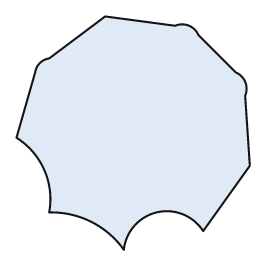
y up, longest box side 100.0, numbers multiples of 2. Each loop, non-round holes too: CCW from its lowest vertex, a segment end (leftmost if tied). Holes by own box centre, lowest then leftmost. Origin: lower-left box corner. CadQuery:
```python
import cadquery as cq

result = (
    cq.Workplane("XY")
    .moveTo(46.0, 0.0)
    .threePointArc((60.0, 16.0), (80.0, 8.0))
    .lineTo(100.0, 36.0)
    .lineTo(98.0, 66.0)
    .threePointArc((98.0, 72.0), (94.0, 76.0))
    .lineTo(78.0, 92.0)
    .threePointArc((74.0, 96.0), (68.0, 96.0))
    .lineTo(38.0, 100.0)
    .lineTo(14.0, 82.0)
    .threePointArc((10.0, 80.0), (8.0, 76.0))
    .lineTo(0.0, 48.0)
    .threePointArc((12.0, 34.0), (14.0, 16.0))
    .threePointArc((32.0, 12.0), (46.0, 0.0))
    .close()
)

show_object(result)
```